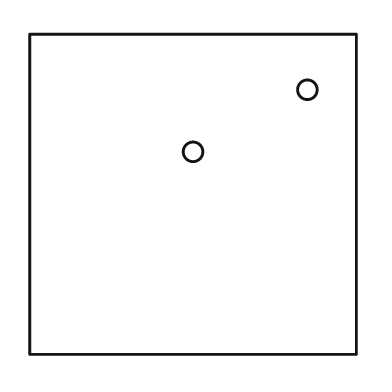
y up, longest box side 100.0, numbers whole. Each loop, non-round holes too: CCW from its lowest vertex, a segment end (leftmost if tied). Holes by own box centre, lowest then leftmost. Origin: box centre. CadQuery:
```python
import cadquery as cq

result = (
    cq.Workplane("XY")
    .moveTo(-50.0, -49.0)
    .lineTo(50.0, -49.0)
    .lineTo(50.0, 49.0)
    .lineTo(-50.0, 49.0)
    .close()
    .moveTo(0.0, 13.0)
    .circle(3.0)
    .moveTo(35.0, 32.0)
    .circle(3.0)
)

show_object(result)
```